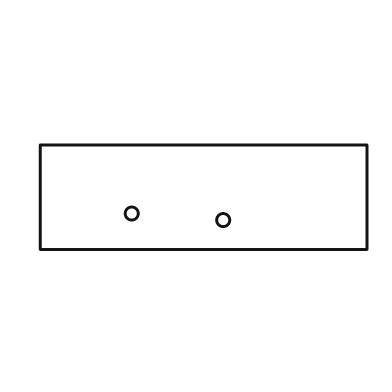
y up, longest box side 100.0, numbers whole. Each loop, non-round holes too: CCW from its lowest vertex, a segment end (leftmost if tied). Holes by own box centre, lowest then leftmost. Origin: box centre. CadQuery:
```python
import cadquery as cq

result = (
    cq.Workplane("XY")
    .moveTo(-50.0, -16.0)
    .lineTo(50.0, -16.0)
    .lineTo(50.0, 16.0)
    .lineTo(-50.0, 16.0)
    .close()
    .moveTo(6.0, -7.0)
    .circle(2.0)
    .moveTo(-22.0, -5.0)
    .circle(2.0)
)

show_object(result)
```